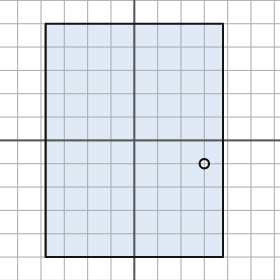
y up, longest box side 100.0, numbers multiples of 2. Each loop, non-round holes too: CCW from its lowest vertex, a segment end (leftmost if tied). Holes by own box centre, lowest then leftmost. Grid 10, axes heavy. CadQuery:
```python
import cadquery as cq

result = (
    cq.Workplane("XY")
    .moveTo(-38.0, -50.0)
    .lineTo(38.0, -50.0)
    .lineTo(38.0, 50.0)
    .lineTo(-38.0, 50.0)
    .close()
    .moveTo(30.0, -10.0)
    .circle(2.0)
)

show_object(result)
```